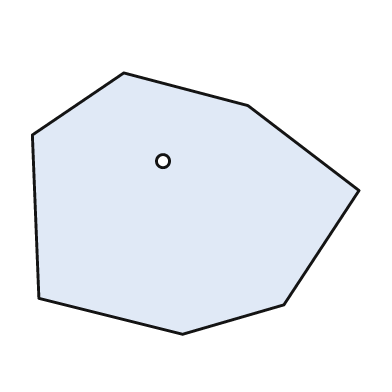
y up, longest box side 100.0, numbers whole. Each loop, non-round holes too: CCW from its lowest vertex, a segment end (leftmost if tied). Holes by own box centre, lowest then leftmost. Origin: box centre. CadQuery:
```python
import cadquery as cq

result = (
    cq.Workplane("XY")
    .moveTo(-4.0, -40.0)
    .lineTo(27.0, -31.0)
    .lineTo(50.0, 4.0)
    .lineTo(16.0, 30.0)
    .lineTo(-22.0, 40.0)
    .lineTo(-50.0, 21.0)
    .lineTo(-48.0, -29.0)
    .close()
    .moveTo(-10.0, 13.0)
    .circle(2.0)
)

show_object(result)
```